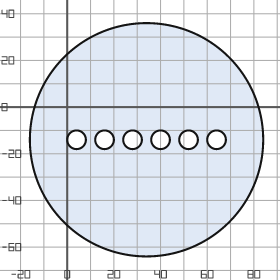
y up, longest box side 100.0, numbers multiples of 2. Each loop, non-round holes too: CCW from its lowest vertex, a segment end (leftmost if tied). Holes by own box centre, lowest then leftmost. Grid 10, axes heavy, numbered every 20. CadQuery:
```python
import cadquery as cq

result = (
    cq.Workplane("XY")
    .moveTo(34.0, -14.0)
    .circle(50.0)
    .moveTo(4.0, -14.0)
    .circle(4.0)
    .moveTo(16.0, -14.0)
    .circle(4.0)
    .moveTo(28.0, -14.0)
    .circle(4.0)
    .moveTo(40.0, -14.0)
    .circle(4.0)
    .moveTo(52.0, -14.0)
    .circle(4.0)
    .moveTo(64.0, -14.0)
    .circle(4.0)
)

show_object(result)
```